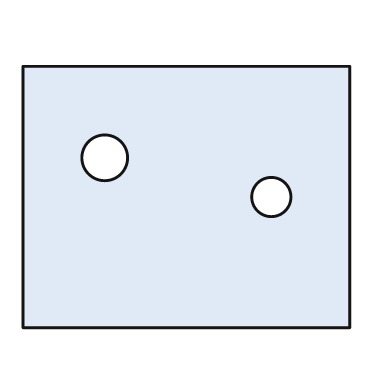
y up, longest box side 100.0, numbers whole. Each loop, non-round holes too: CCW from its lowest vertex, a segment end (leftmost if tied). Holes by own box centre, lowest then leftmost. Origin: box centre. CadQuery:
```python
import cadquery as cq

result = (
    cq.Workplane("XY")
    .moveTo(-50.0, -40.0)
    .lineTo(50.0, -40.0)
    .lineTo(50.0, 40.0)
    .lineTo(-50.0, 40.0)
    .close()
    .moveTo(26.0, 0.0)
    .circle(6.0)
    .moveTo(-25.0, 12.0)
    .circle(7.0)
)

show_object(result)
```